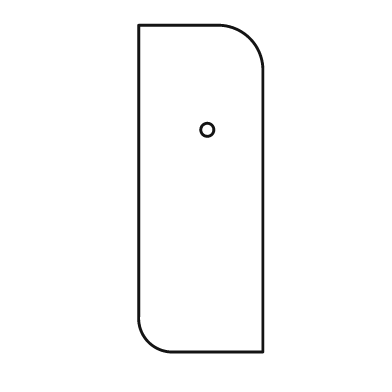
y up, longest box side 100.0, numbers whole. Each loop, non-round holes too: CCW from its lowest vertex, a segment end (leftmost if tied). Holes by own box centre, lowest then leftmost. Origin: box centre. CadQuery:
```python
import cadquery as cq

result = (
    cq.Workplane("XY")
    .moveTo(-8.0, -50.0)
    .lineTo(19.0, -50.0)
    .lineTo(19.0, 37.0)
    .threePointArc((15.0, 46.0), (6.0, 50.0))
    .lineTo(-19.0, 50.0)
    .lineTo(-19.0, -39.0)
    .threePointArc((-16.0, -47.0), (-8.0, -50.0))
    .close()
    .moveTo(2.0, 18.0)
    .circle(2.0)
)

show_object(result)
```